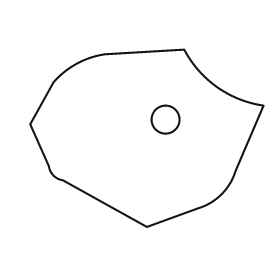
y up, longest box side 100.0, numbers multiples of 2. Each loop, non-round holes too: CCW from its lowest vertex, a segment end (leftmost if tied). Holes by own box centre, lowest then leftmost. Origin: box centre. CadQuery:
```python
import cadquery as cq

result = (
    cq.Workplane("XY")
    .moveTo(0.0, -38.0)
    .lineTo(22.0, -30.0)
    .threePointArc((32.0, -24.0), (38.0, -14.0))
    .lineTo(50.0, 14.0)
    .threePointArc((30.0, 22.0), (16.0, 38.0))
    .lineTo(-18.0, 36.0)
    .threePointArc((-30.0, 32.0), (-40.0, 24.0))
    .lineTo(-50.0, 6.0)
    .lineTo(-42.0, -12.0)
    .threePointArc((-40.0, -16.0), (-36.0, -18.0))
    .close()
    .moveTo(8.0, 8.0)
    .circle(6.0)
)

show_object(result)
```